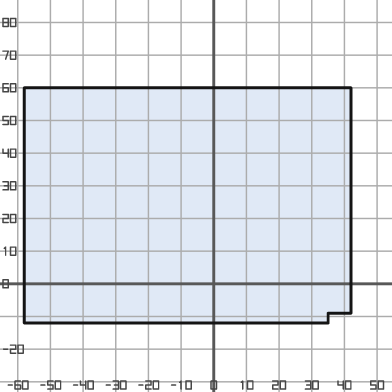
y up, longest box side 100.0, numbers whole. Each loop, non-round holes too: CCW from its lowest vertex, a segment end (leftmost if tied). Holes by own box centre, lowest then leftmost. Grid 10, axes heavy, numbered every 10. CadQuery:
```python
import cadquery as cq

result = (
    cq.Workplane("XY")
    .moveTo(-58.0, -12.0)
    .lineTo(35.0, -12.0)
    .lineTo(35.0, -9.0)
    .lineTo(42.0, -9.0)
    .lineTo(42.0, 60.0)
    .lineTo(-58.0, 60.0)
    .close()
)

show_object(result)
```